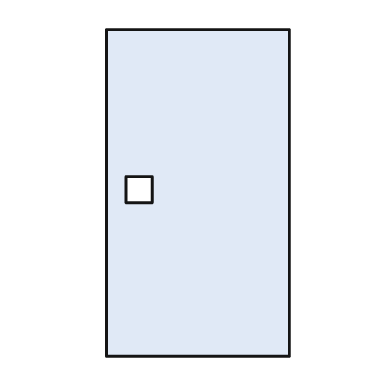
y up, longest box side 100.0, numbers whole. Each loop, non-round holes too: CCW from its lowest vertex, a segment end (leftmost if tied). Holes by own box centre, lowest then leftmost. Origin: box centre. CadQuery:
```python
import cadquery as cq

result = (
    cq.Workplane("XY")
    .moveTo(-28.0, -50.0)
    .lineTo(28.0, -50.0)
    .lineTo(28.0, 50.0)
    .lineTo(-28.0, 50.0)
    .close()
    .moveTo(-22.0, -3.0)
    .lineTo(-14.0, -3.0)
    .lineTo(-14.0, 5.0)
    .lineTo(-22.0, 5.0)
    .close()
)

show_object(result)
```